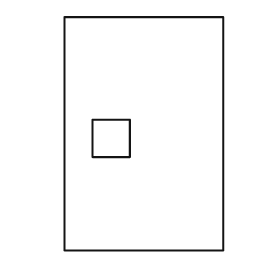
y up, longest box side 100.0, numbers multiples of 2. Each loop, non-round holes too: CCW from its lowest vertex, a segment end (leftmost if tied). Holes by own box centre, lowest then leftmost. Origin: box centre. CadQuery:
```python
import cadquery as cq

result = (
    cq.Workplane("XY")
    .moveTo(-34.0, -50.0)
    .lineTo(34.0, -50.0)
    .lineTo(34.0, 50.0)
    .lineTo(-34.0, 50.0)
    .close()
    .moveTo(-22.0, -10.0)
    .lineTo(-6.0, -10.0)
    .lineTo(-6.0, 6.0)
    .lineTo(-22.0, 6.0)
    .close()
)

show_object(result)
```